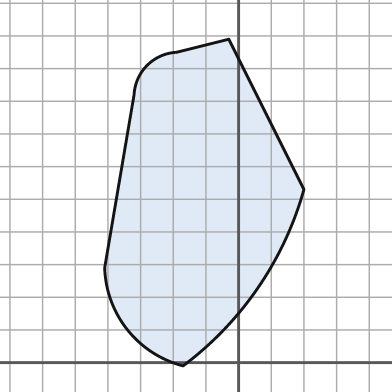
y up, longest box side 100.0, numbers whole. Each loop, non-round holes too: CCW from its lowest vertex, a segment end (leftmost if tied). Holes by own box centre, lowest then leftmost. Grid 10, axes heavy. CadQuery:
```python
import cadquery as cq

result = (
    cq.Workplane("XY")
    .moveTo(-17.0, -1.0)
    .threePointArc((6.0, 23.0), (20.0, 53.0))
    .lineTo(-3.0, 99.0)
    .lineTo(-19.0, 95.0)
    .threePointArc((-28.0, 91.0), (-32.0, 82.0))
    .lineTo(-41.0, 29.0)
    .threePointArc((-34.0, 10.0), (-17.0, -1.0))
    .close()
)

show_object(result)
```